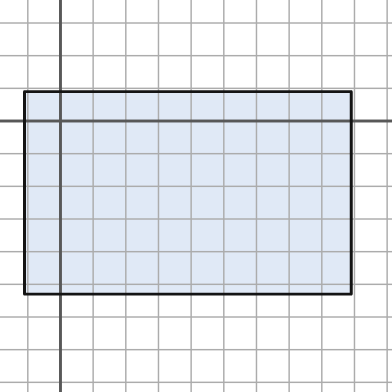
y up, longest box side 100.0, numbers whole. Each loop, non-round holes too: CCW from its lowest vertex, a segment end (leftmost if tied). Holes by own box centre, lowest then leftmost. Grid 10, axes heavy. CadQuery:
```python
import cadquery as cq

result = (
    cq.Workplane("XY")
    .moveTo(-11.0, -53.0)
    .lineTo(89.0, -53.0)
    .lineTo(89.0, 9.0)
    .lineTo(-11.0, 9.0)
    .close()
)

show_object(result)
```